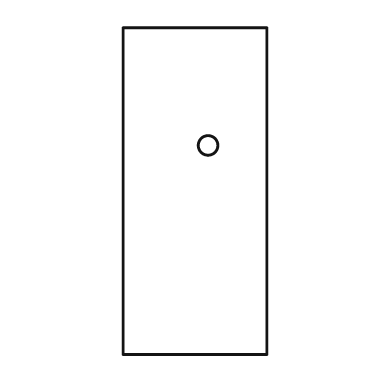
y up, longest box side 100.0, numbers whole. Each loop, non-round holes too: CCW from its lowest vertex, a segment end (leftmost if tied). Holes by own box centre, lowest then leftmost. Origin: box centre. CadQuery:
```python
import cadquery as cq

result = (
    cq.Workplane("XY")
    .moveTo(-22.0, -50.0)
    .lineTo(22.0, -50.0)
    .lineTo(22.0, 50.0)
    .lineTo(-22.0, 50.0)
    .close()
    .moveTo(4.0, 14.0)
    .circle(3.0)
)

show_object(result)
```